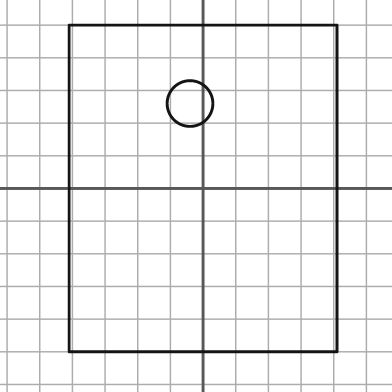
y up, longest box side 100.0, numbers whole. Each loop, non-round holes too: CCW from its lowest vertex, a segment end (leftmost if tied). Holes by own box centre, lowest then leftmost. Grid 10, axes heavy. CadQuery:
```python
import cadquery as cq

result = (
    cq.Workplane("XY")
    .moveTo(-41.0, -50.0)
    .lineTo(41.0, -50.0)
    .lineTo(41.0, 50.0)
    .lineTo(-41.0, 50.0)
    .close()
    .moveTo(-4.0, 26.0)
    .circle(7.0)
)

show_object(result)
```